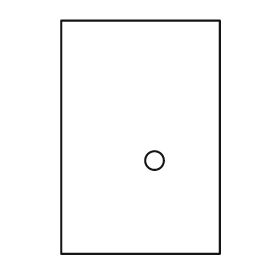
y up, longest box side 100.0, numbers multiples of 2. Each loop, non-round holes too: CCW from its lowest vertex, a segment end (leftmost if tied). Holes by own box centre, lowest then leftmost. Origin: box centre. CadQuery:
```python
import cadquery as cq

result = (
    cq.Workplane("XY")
    .moveTo(-34.0, -50.0)
    .lineTo(34.0, -50.0)
    .lineTo(34.0, 50.0)
    .lineTo(-34.0, 50.0)
    .close()
    .moveTo(6.0, -10.0)
    .circle(4.0)
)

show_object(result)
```